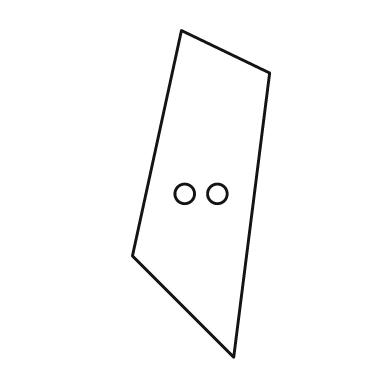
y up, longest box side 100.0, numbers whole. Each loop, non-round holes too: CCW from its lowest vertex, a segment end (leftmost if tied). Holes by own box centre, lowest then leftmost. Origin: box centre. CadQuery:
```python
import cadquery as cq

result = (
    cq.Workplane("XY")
    .moveTo(10.0, -50.0)
    .lineTo(21.0, 37.0)
    .lineTo(-6.0, 50.0)
    .lineTo(-21.0, -19.0)
    .close()
    .moveTo(-5.0, 0.0)
    .circle(3.0)
    .moveTo(5.0, 0.0)
    .circle(3.0)
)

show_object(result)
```